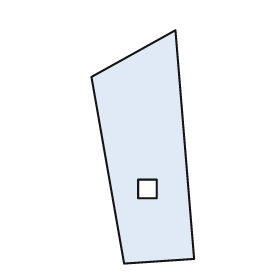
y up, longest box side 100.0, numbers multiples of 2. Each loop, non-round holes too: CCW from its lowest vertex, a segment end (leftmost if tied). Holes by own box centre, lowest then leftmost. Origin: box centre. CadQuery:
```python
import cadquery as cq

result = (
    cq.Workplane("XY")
    .moveTo(-8.0, -50.0)
    .lineTo(22.0, -48.0)
    .lineTo(14.0, 50.0)
    .lineTo(-22.0, 30.0)
    .close()
    .moveTo(-2.0, -22.0)
    .lineTo(6.0, -22.0)
    .lineTo(6.0, -14.0)
    .lineTo(-2.0, -14.0)
    .close()
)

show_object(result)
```